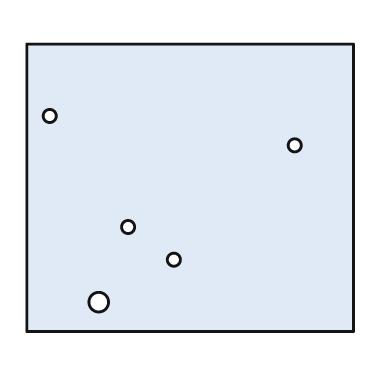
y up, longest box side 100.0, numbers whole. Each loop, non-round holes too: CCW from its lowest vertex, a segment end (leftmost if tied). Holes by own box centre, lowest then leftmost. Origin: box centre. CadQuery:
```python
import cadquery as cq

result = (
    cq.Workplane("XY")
    .moveTo(-50.0, -44.0)
    .lineTo(50.0, -44.0)
    .lineTo(50.0, 44.0)
    .lineTo(-50.0, 44.0)
    .close()
    .moveTo(-28.0, -35.0)
    .circle(3.0)
    .moveTo(-5.0, -22.0)
    .circle(2.0)
    .moveTo(-19.0, -12.0)
    .circle(2.0)
    .moveTo(32.0, 13.0)
    .circle(2.0)
    .moveTo(-43.0, 22.0)
    .circle(2.0)
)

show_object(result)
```